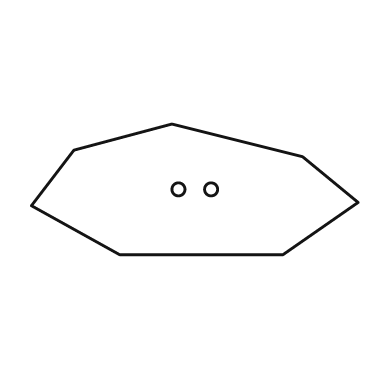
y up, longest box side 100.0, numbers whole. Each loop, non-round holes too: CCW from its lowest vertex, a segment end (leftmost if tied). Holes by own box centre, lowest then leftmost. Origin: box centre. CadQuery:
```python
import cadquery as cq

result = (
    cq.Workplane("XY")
    .moveTo(-23.0, -20.0)
    .lineTo(27.0, -20.0)
    .lineTo(50.0, -4.0)
    .lineTo(33.0, 10.0)
    .lineTo(-7.0, 20.0)
    .lineTo(-37.0, 12.0)
    .lineTo(-50.0, -5.0)
    .close()
    .moveTo(-5.0, 0.0)
    .circle(2.0)
    .moveTo(5.0, 0.0)
    .circle(2.0)
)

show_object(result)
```